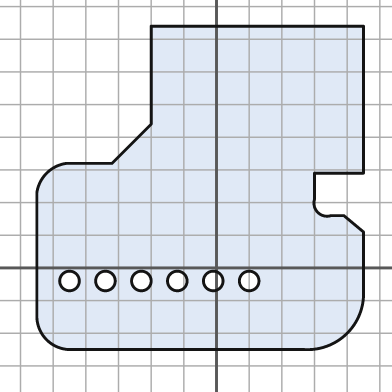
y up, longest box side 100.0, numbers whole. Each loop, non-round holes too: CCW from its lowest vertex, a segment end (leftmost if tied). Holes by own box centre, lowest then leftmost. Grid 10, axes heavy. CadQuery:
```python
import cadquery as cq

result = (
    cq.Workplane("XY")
    .moveTo(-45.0, -25.0)
    .lineTo(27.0, -25.0)
    .threePointArc((40.0, -20.0), (45.0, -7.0))
    .lineTo(45.0, 11.0)
    .lineTo(39.0, 16.0)
    .lineTo(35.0, 16.0)
    .threePointArc((31.0, 17.0), (30.0, 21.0))
    .lineTo(30.0, 29.0)
    .lineTo(45.0, 29.0)
    .lineTo(45.0, 74.0)
    .lineTo(-20.0, 74.0)
    .lineTo(-20.0, 44.0)
    .lineTo(-32.0, 32.0)
    .lineTo(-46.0, 32.0)
    .threePointArc((-52.0, 29.0), (-55.0, 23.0))
    .lineTo(-55.0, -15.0)
    .threePointArc((-52.0, -22.0), (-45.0, -25.0))
    .close()
    .moveTo(-45.0, -4.0)
    .circle(3.0)
    .moveTo(-34.0, -4.0)
    .circle(3.0)
    .moveTo(-23.0, -4.0)
    .circle(3.0)
    .moveTo(-12.0, -4.0)
    .circle(3.0)
    .moveTo(-1.0, -4.0)
    .circle(3.0)
    .moveTo(10.0, -4.0)
    .circle(3.0)
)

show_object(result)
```